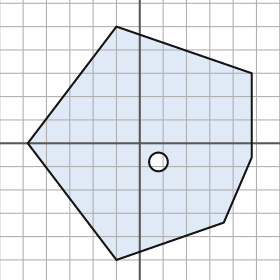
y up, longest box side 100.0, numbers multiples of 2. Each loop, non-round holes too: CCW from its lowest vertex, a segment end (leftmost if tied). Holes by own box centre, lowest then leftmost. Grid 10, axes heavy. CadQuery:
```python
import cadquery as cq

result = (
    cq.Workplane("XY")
    .moveTo(-10.0, -50.0)
    .lineTo(36.0, -34.0)
    .lineTo(48.0, -6.0)
    .lineTo(48.0, 30.0)
    .lineTo(-10.0, 50.0)
    .lineTo(-48.0, 0.0)
    .close()
    .moveTo(8.0, -8.0)
    .circle(4.0)
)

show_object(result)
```